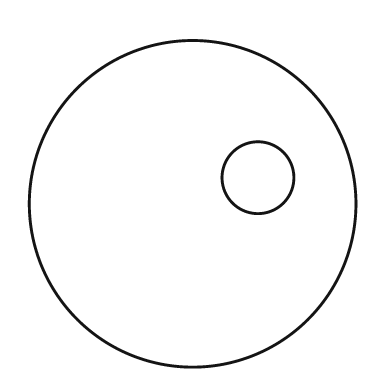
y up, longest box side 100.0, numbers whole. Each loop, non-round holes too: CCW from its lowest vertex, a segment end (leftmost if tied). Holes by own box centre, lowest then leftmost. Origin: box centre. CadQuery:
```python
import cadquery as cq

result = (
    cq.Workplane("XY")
    .moveTo(0.0, 0.0)
    .circle(50.0)
    .moveTo(20.0, 8.0)
    .circle(11.0)
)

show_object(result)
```